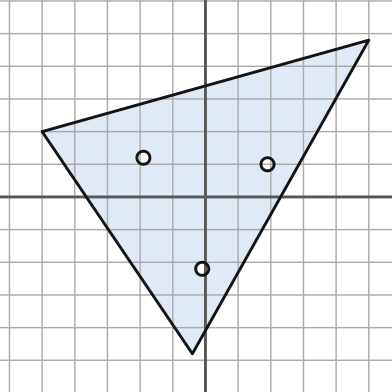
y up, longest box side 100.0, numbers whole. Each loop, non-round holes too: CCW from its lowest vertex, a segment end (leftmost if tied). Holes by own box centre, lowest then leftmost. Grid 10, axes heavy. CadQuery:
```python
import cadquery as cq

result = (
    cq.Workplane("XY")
    .moveTo(-4.0, -48.0)
    .lineTo(50.0, 48.0)
    .lineTo(-50.0, 20.0)
    .close()
    .moveTo(-1.0, -22.0)
    .circle(2.0)
    .moveTo(19.0, 10.0)
    .circle(2.0)
    .moveTo(-19.0, 12.0)
    .circle(2.0)
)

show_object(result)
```